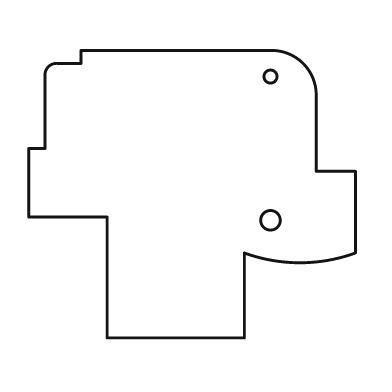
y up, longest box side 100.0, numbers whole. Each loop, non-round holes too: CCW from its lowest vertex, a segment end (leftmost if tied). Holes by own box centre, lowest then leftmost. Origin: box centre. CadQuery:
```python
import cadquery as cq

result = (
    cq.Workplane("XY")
    .moveTo(-26.0, -44.0)
    .lineTo(16.0, -44.0)
    .lineTo(16.0, -18.0)
    .threePointArc((33.0, -21.0), (50.0, -18.0))
    .lineTo(50.0, 7.0)
    .lineTo(38.0, 7.0)
    .lineTo(38.0, 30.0)
    .threePointArc((34.0, 40.0), (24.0, 44.0))
    .lineTo(-34.0, 44.0)
    .lineTo(-34.0, 40.0)
    .lineTo(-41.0, 40.0)
    .threePointArc((-44.0, 39.0), (-45.0, 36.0))
    .lineTo(-45.0, 14.0)
    .lineTo(-50.0, 14.0)
    .lineTo(-50.0, -7.0)
    .lineTo(-26.0, -7.0)
    .close()
    .moveTo(24.0, -8.0)
    .circle(3.0)
    .moveTo(24.0, 36.0)
    .circle(2.0)
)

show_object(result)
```